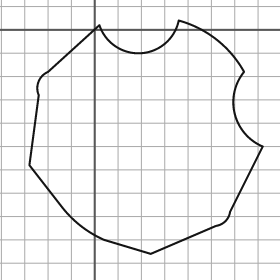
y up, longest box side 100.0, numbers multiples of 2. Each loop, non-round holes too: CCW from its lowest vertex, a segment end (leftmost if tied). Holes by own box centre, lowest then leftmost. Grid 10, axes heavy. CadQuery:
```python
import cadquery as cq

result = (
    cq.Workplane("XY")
    .moveTo(24.0, -96.0)
    .lineTo(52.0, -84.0)
    .threePointArc((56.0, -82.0), (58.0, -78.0))
    .lineTo(72.0, -50.0)
    .threePointArc((60.0, -36.0), (64.0, -18.0))
    .threePointArc((52.0, -4.0), (36.0, 4.0))
    .threePointArc((20.0, -10.0), (2.0, 2.0))
    .lineTo(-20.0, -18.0)
    .threePointArc((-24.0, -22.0), (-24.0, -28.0))
    .lineTo(-28.0, -58.0)
    .lineTo(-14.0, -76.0)
    .threePointArc((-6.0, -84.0), (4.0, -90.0))
    .close()
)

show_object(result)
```